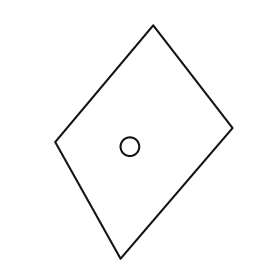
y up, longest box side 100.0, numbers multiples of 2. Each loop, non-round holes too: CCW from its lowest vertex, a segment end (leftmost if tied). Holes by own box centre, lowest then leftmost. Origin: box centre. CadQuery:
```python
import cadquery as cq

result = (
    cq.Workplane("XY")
    .moveTo(-10.0, -50.0)
    .lineTo(38.0, 6.0)
    .lineTo(4.0, 50.0)
    .lineTo(-38.0, 0.0)
    .close()
    .moveTo(-6.0, -2.0)
    .circle(4.0)
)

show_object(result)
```